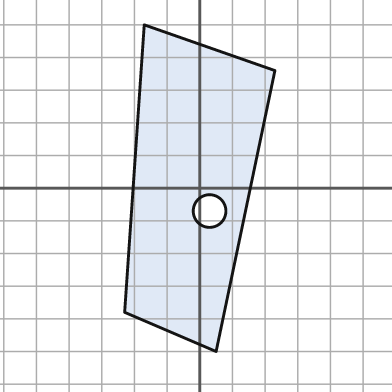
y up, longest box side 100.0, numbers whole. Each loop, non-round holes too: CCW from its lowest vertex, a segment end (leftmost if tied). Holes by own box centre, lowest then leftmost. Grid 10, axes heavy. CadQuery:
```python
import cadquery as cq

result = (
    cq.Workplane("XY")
    .moveTo(5.0, -50.0)
    .lineTo(23.0, 36.0)
    .lineTo(-17.0, 50.0)
    .lineTo(-23.0, -38.0)
    .close()
    .moveTo(3.0, -7.0)
    .circle(5.0)
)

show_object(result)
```